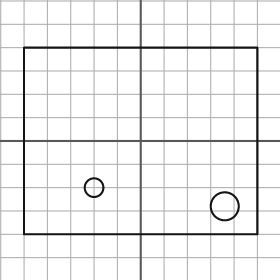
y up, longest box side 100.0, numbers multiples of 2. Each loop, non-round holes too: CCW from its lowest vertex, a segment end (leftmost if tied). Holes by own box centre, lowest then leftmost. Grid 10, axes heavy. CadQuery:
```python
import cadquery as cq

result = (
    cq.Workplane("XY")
    .moveTo(-50.0, -40.0)
    .lineTo(50.0, -40.0)
    .lineTo(50.0, 40.0)
    .lineTo(-50.0, 40.0)
    .close()
    .moveTo(36.0, -28.0)
    .circle(6.0)
    .moveTo(-20.0, -20.0)
    .circle(4.0)
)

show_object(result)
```